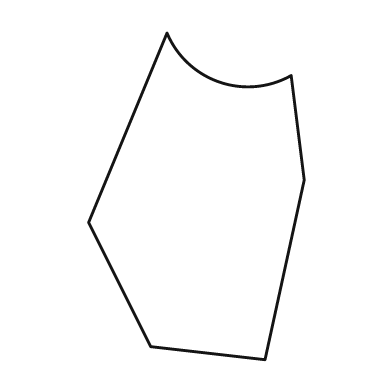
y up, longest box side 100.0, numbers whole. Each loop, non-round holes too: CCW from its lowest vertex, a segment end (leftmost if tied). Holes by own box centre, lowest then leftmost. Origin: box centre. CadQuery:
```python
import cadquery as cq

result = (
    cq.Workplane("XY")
    .moveTo(21.0, -50.0)
    .lineTo(33.0, 5.0)
    .lineTo(29.0, 37.0)
    .threePointArc((7.0, 35.0), (-9.0, 50.0))
    .lineTo(-33.0, -8.0)
    .lineTo(-14.0, -46.0)
    .close()
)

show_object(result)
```